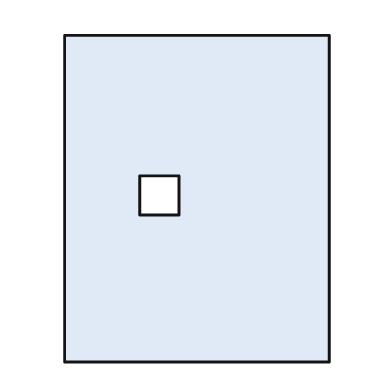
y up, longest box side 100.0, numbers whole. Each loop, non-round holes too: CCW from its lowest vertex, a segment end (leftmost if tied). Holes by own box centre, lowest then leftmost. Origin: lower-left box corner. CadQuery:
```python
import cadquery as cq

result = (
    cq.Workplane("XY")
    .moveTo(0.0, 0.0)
    .lineTo(81.0, 0.0)
    .lineTo(81.0, 100.0)
    .lineTo(0.0, 100.0)
    .close()
    .moveTo(23.0, 45.0)
    .lineTo(35.0, 45.0)
    .lineTo(35.0, 57.0)
    .lineTo(23.0, 57.0)
    .close()
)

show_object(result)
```